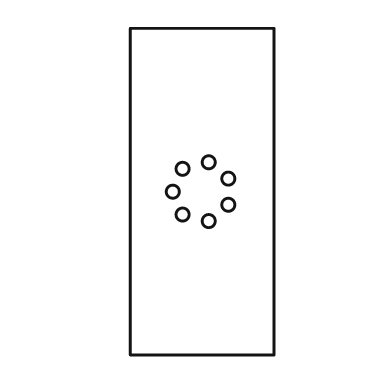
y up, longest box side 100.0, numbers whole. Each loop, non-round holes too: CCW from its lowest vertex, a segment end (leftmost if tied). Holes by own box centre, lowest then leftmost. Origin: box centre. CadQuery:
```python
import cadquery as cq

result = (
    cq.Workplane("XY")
    .moveTo(-22.0, -50.0)
    .lineTo(22.0, -50.0)
    .lineTo(22.0, 50.0)
    .lineTo(-22.0, 50.0)
    .close()
    .moveTo(2.0, -9.0)
    .circle(2.0)
    .moveTo(-6.0, -7.0)
    .circle(2.0)
    .moveTo(8.0, -4.0)
    .circle(2.0)
    .moveTo(-9.0, 0.0)
    .circle(2.0)
    .moveTo(8.0, 4.0)
    .circle(2.0)
    .moveTo(-6.0, 7.0)
    .circle(2.0)
    .moveTo(2.0, 9.0)
    .circle(2.0)
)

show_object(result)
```